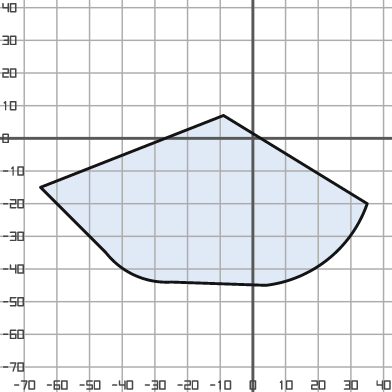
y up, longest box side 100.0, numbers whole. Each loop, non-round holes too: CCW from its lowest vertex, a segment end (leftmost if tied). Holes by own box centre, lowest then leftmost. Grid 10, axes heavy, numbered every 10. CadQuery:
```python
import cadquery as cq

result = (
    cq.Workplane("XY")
    .moveTo(4.0, -45.0)
    .threePointArc((23.0, -37.0), (35.0, -20.0))
    .lineTo(-9.0, 7.0)
    .lineTo(-65.0, -15.0)
    .lineTo(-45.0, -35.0)
    .threePointArc((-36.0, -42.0), (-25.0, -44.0))
    .close()
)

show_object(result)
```